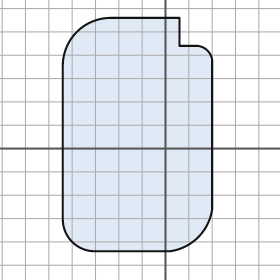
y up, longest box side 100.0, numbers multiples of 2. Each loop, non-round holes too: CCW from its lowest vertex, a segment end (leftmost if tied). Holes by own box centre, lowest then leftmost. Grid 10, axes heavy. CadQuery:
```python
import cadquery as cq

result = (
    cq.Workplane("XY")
    .moveTo(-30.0, -44.0)
    .lineTo(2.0, -44.0)
    .threePointArc((14.0, -38.0), (20.0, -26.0))
    .lineTo(20.0, 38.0)
    .threePointArc((18.0, 42.0), (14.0, 44.0))
    .lineTo(6.0, 44.0)
    .lineTo(6.0, 56.0)
    .lineTo(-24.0, 56.0)
    .threePointArc((-38.0, 50.0), (-44.0, 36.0))
    .lineTo(-44.0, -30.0)
    .threePointArc((-40.0, -40.0), (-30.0, -44.0))
    .close()
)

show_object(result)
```